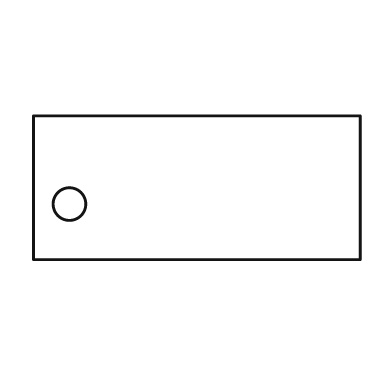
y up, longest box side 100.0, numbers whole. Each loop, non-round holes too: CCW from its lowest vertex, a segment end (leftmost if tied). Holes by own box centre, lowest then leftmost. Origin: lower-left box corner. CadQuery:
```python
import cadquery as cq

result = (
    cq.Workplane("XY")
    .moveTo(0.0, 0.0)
    .lineTo(100.0, 0.0)
    .lineTo(100.0, 44.0)
    .lineTo(0.0, 44.0)
    .close()
    .moveTo(11.0, 17.0)
    .circle(5.0)
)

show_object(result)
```